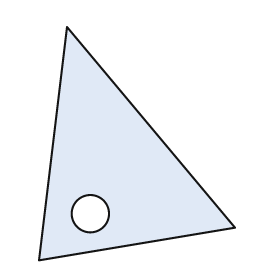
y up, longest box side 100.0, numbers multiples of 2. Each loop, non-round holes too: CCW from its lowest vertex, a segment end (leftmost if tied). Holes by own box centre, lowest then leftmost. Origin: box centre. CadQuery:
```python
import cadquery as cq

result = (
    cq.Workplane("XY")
    .moveTo(-42.0, -50.0)
    .lineTo(42.0, -36.0)
    .lineTo(-30.0, 50.0)
    .close()
    .moveTo(-20.0, -30.0)
    .circle(8.0)
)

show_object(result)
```